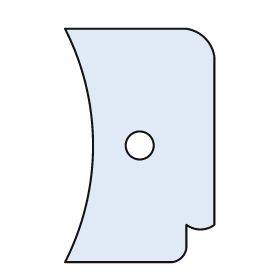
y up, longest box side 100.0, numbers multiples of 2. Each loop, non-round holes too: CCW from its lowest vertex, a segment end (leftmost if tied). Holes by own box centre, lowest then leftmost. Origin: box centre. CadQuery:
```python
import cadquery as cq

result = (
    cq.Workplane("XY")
    .moveTo(-32.0, -50.0)
    .lineTo(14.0, -50.0)
    .threePointArc((18.0, -48.0), (20.0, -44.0))
    .lineTo(20.0, -34.0)
    .threePointArc((26.0, -36.0), (32.0, -34.0))
    .lineTo(32.0, 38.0)
    .threePointArc((28.0, 46.0), (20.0, 50.0))
    .lineTo(-32.0, 50.0)
    .threePointArc((-20.0, 0.0), (-32.0, -50.0))
    .close()
    .moveTo(0.0, 0.0)
    .circle(6.0)
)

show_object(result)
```